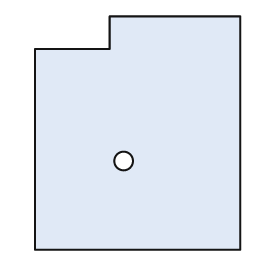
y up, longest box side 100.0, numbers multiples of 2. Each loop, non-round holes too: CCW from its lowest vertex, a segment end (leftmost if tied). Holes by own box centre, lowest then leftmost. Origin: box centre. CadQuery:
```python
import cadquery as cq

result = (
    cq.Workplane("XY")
    .moveTo(-44.0, -50.0)
    .lineTo(44.0, -50.0)
    .lineTo(44.0, 50.0)
    .lineTo(-12.0, 50.0)
    .lineTo(-12.0, 36.0)
    .lineTo(-44.0, 36.0)
    .close()
    .moveTo(-6.0, -12.0)
    .circle(4.0)
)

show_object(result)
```